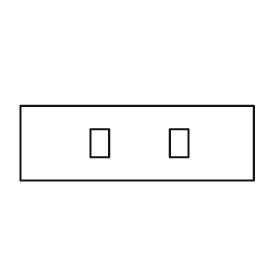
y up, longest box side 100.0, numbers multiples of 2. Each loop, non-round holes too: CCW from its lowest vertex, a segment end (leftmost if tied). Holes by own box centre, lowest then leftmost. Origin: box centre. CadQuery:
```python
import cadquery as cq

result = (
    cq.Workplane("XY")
    .moveTo(-50.0, -16.0)
    .lineTo(50.0, -16.0)
    .lineTo(50.0, 16.0)
    .lineTo(-50.0, 16.0)
    .close()
    .moveTo(-20.0, -6.0)
    .lineTo(-12.0, -6.0)
    .lineTo(-12.0, 6.0)
    .lineTo(-20.0, 6.0)
    .close()
    .moveTo(14.0, -6.0)
    .lineTo(22.0, -6.0)
    .lineTo(22.0, 6.0)
    .lineTo(14.0, 6.0)
    .close()
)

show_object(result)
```